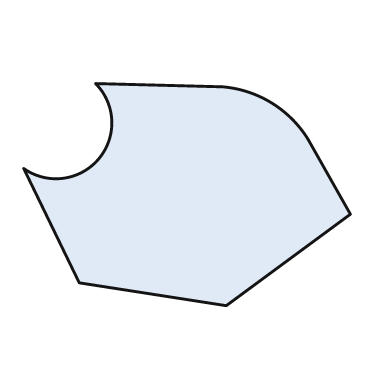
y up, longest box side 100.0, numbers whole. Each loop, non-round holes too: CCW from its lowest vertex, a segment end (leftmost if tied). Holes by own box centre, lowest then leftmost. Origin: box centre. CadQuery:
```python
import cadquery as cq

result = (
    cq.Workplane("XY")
    .moveTo(12.0, -34.0)
    .lineTo(50.0, -6.0)
    .lineTo(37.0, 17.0)
    .threePointArc((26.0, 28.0), (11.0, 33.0))
    .lineTo(-28.0, 34.0)
    .threePointArc((-27.0, 11.0), (-50.0, 8.0))
    .lineTo(-33.0, -27.0)
    .close()
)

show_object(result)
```